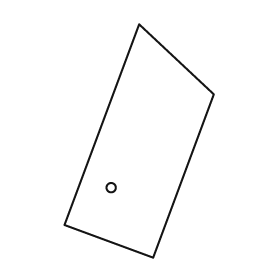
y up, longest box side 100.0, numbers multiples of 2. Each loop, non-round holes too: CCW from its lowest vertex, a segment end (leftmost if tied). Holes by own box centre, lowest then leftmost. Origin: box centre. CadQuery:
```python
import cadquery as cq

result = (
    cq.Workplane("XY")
    .moveTo(6.0, -50.0)
    .lineTo(32.0, 20.0)
    .lineTo(0.0, 50.0)
    .lineTo(-32.0, -36.0)
    .close()
    .moveTo(-12.0, -20.0)
    .circle(2.0)
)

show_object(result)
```